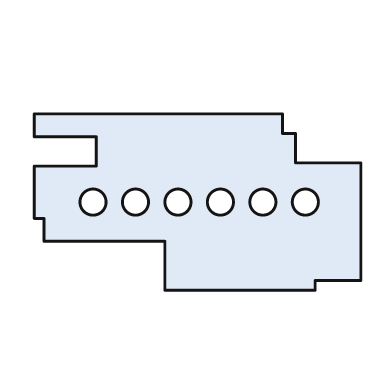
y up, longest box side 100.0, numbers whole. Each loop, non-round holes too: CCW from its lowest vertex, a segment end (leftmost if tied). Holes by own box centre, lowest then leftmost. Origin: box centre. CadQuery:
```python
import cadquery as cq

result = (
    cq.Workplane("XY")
    .moveTo(-10.0, -27.0)
    .lineTo(36.0, -27.0)
    .lineTo(36.0, -24.0)
    .lineTo(50.0, -24.0)
    .lineTo(50.0, 12.0)
    .lineTo(30.0, 12.0)
    .lineTo(30.0, 21.0)
    .lineTo(26.0, 21.0)
    .lineTo(26.0, 27.0)
    .lineTo(-50.0, 27.0)
    .lineTo(-50.0, 20.0)
    .lineTo(-31.0, 20.0)
    .lineTo(-31.0, 11.0)
    .lineTo(-50.0, 11.0)
    .lineTo(-50.0, -5.0)
    .lineTo(-47.0, -5.0)
    .lineTo(-47.0, -12.0)
    .lineTo(-10.0, -12.0)
    .close()
    .moveTo(-32.0, 0.0)
    .circle(4.0)
    .moveTo(-19.0, 0.0)
    .circle(4.0)
    .moveTo(-6.0, 0.0)
    .circle(4.0)
    .moveTo(7.0, 0.0)
    .circle(4.0)
    .moveTo(20.0, 0.0)
    .circle(4.0)
    .moveTo(33.0, 0.0)
    .circle(4.0)
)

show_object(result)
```